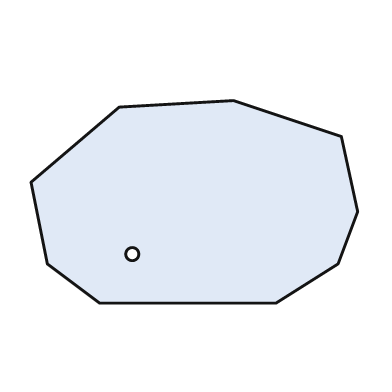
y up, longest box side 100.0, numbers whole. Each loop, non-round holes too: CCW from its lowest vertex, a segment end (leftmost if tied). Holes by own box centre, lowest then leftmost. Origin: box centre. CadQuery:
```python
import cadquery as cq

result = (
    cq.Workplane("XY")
    .moveTo(-29.0, -31.0)
    .lineTo(25.0, -31.0)
    .lineTo(44.0, -19.0)
    .lineTo(50.0, -3.0)
    .lineTo(45.0, 20.0)
    .lineTo(12.0, 31.0)
    .lineTo(-23.0, 29.0)
    .lineTo(-50.0, 6.0)
    .lineTo(-45.0, -19.0)
    .close()
    .moveTo(-19.0, -16.0)
    .circle(2.0)
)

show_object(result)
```